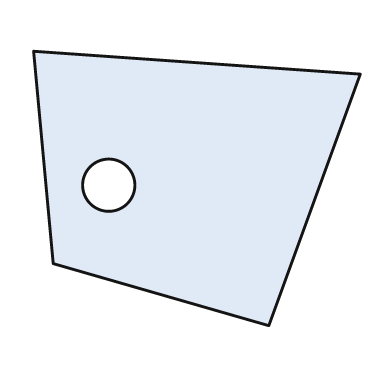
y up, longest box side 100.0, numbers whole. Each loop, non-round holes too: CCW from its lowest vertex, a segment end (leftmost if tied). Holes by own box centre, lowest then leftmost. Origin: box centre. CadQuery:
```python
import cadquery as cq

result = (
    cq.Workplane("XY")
    .moveTo(22.0, -42.0)
    .lineTo(50.0, 35.0)
    .lineTo(-50.0, 42.0)
    .lineTo(-44.0, -23.0)
    .close()
    .moveTo(-27.0, 1.0)
    .circle(8.0)
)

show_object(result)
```